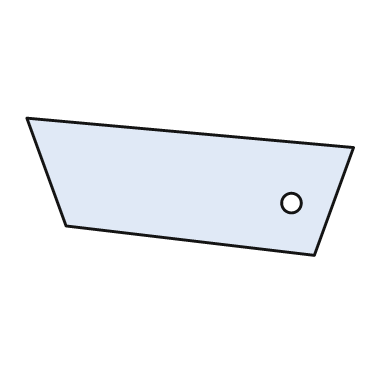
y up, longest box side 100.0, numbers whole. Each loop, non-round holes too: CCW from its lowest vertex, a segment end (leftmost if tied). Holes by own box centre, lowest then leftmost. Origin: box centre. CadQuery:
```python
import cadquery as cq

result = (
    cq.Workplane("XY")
    .moveTo(38.0, -21.0)
    .lineTo(50.0, 12.0)
    .lineTo(-50.0, 21.0)
    .lineTo(-38.0, -12.0)
    .close()
    .moveTo(31.0, -5.0)
    .circle(3.0)
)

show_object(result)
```